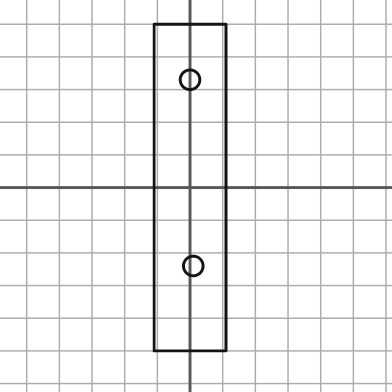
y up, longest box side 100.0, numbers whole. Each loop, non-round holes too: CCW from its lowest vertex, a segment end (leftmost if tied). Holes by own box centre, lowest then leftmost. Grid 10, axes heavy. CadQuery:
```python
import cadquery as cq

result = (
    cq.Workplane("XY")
    .moveTo(-11.0, -50.0)
    .lineTo(11.0, -50.0)
    .lineTo(11.0, 50.0)
    .lineTo(-11.0, 50.0)
    .close()
    .moveTo(1.0, -24.0)
    .circle(3.0)
    .moveTo(0.0, 33.0)
    .circle(3.0)
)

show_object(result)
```